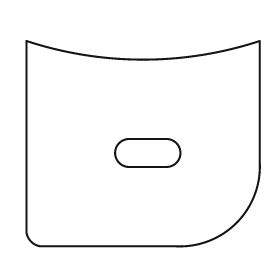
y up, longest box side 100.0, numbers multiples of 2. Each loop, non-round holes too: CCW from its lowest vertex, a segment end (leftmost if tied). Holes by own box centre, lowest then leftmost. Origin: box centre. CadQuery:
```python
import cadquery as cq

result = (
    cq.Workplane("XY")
    .moveTo(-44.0, -44.0)
    .lineTo(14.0, -44.0)
    .threePointArc((40.0, -34.0), (50.0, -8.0))
    .lineTo(50.0, 44.0)
    .threePointArc((0.0, 36.0), (-50.0, 44.0))
    .lineTo(-50.0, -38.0)
    .threePointArc((-48.0, -42.0), (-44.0, -44.0))
    .close()
    .moveTo(-6.0, -10.0)
    .lineTo(10.0, -10.0)
    .threePointArc((16.0, -4.0), (10.0, 2.0))
    .lineTo(-6.0, 2.0)
    .threePointArc((-12.0, -4.0), (-6.0, -10.0))
    .close()
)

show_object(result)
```